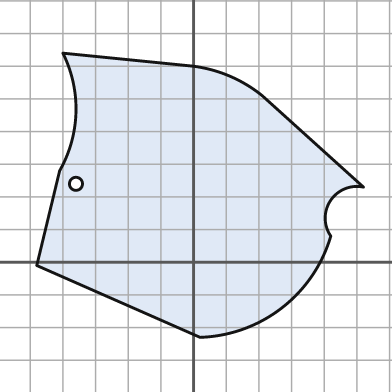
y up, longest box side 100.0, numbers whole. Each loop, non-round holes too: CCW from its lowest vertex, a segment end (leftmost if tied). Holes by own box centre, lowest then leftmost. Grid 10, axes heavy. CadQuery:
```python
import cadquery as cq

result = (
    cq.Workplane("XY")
    .moveTo(2.0, -23.0)
    .threePointArc((27.0, -14.0), (42.0, 8.0))
    .threePointArc((42.0, 19.0), (52.0, 23.0))
    .lineTo(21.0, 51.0)
    .threePointArc((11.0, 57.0), (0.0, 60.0))
    .lineTo(-40.0, 64.0)
    .threePointArc((-36.0, 46.0), (-41.0, 28.0))
    .lineTo(-48.0, -1.0)
    .close()
    .moveTo(-36.0, 24.0)
    .circle(2.0)
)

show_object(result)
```